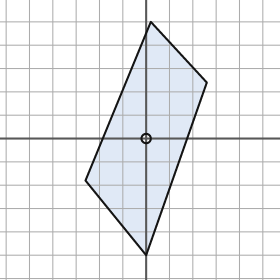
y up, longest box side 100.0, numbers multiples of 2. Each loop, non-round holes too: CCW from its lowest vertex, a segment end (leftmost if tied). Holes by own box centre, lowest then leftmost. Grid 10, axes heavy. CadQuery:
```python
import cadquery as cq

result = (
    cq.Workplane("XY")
    .moveTo(0.0, -50.0)
    .lineTo(26.0, 24.0)
    .lineTo(2.0, 50.0)
    .lineTo(-26.0, -18.0)
    .close()
    .moveTo(0.0, 0.0)
    .circle(2.0)
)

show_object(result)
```